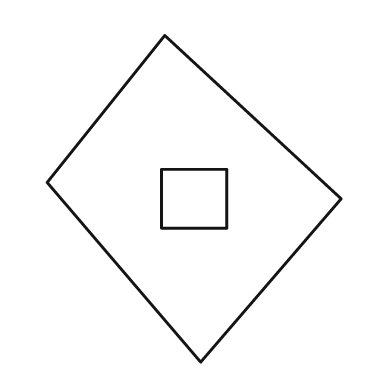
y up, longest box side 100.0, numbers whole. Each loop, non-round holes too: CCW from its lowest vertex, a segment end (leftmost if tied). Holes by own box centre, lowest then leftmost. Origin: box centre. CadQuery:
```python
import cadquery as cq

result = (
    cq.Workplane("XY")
    .moveTo(2.0, -50.0)
    .lineTo(45.0, 0.0)
    .lineTo(-9.0, 50.0)
    .lineTo(-45.0, 5.0)
    .close()
    .moveTo(-10.0, -9.0)
    .lineTo(10.0, -9.0)
    .lineTo(10.0, 9.0)
    .lineTo(-10.0, 9.0)
    .close()
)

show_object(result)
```